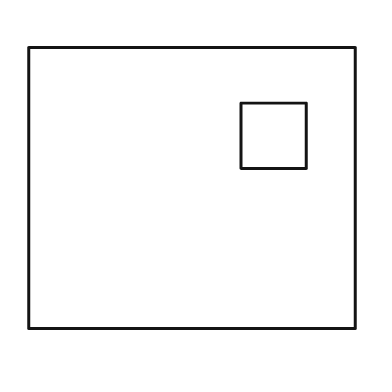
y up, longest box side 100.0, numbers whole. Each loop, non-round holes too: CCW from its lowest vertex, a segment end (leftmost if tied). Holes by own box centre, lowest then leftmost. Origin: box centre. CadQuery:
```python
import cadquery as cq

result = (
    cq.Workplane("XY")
    .moveTo(-50.0, -43.0)
    .lineTo(50.0, -43.0)
    .lineTo(50.0, 43.0)
    .lineTo(-50.0, 43.0)
    .close()
    .moveTo(15.0, 6.0)
    .lineTo(35.0, 6.0)
    .lineTo(35.0, 26.0)
    .lineTo(15.0, 26.0)
    .close()
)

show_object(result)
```